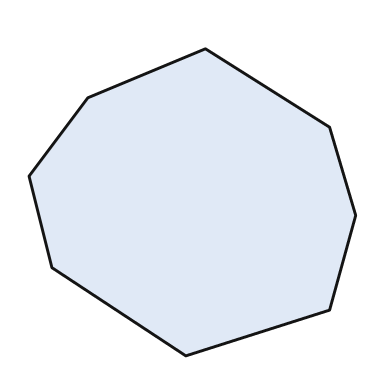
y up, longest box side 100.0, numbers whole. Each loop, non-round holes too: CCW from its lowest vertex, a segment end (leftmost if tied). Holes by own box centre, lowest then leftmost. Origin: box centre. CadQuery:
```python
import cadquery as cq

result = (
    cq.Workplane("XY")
    .moveTo(-2.0, -47.0)
    .lineTo(42.0, -33.0)
    .lineTo(50.0, -4.0)
    .lineTo(42.0, 23.0)
    .lineTo(4.0, 47.0)
    .lineTo(-32.0, 32.0)
    .lineTo(-50.0, 8.0)
    .lineTo(-43.0, -20.0)
    .close()
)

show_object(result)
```